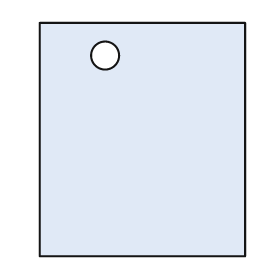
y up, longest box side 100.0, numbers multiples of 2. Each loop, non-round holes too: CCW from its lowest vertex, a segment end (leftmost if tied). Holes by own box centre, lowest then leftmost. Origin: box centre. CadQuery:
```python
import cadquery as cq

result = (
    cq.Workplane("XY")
    .moveTo(-44.0, -50.0)
    .lineTo(44.0, -50.0)
    .lineTo(44.0, 50.0)
    .lineTo(-44.0, 50.0)
    .close()
    .moveTo(-16.0, 36.0)
    .circle(6.0)
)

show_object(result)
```